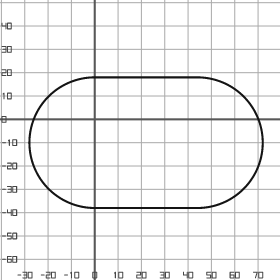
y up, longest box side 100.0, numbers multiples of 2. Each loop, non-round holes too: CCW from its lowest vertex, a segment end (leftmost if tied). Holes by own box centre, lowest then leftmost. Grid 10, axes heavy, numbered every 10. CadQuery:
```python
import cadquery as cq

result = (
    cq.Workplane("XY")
    .moveTo(0.0, -38.0)
    .lineTo(44.0, -38.0)
    .threePointArc((72.0, -10.0), (44.0, 18.0))
    .lineTo(0.0, 18.0)
    .threePointArc((-28.0, -10.0), (0.0, -38.0))
    .close()
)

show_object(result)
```